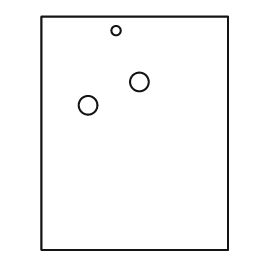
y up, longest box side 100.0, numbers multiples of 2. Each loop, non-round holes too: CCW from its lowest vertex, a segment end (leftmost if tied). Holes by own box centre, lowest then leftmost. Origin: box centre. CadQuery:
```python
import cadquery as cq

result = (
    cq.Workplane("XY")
    .moveTo(-40.0, -50.0)
    .lineTo(40.0, -50.0)
    .lineTo(40.0, 50.0)
    .lineTo(-40.0, 50.0)
    .close()
    .moveTo(-20.0, 12.0)
    .circle(4.0)
    .moveTo(2.0, 22.0)
    .circle(4.0)
    .moveTo(-8.0, 44.0)
    .circle(2.0)
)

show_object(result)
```